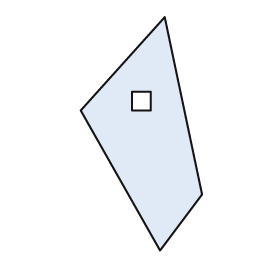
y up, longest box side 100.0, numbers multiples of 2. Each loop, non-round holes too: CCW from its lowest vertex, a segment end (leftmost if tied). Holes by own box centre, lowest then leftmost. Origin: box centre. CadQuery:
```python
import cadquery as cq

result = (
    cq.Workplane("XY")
    .moveTo(8.0, -50.0)
    .lineTo(26.0, -26.0)
    .lineTo(10.0, 50.0)
    .lineTo(-26.0, 10.0)
    .close()
    .moveTo(-4.0, 10.0)
    .lineTo(4.0, 10.0)
    .lineTo(4.0, 18.0)
    .lineTo(-4.0, 18.0)
    .close()
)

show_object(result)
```